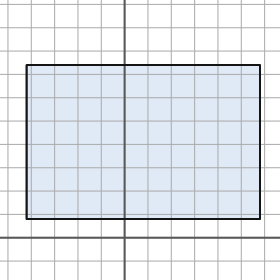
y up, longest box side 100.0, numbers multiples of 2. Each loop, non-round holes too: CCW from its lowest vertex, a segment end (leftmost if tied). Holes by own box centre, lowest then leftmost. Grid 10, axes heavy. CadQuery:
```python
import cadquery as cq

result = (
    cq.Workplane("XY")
    .moveTo(-42.0, 8.0)
    .lineTo(58.0, 8.0)
    .lineTo(58.0, 74.0)
    .lineTo(-42.0, 74.0)
    .close()
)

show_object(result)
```